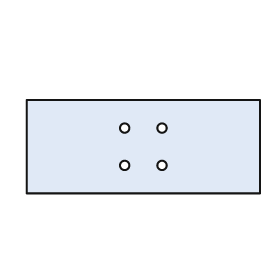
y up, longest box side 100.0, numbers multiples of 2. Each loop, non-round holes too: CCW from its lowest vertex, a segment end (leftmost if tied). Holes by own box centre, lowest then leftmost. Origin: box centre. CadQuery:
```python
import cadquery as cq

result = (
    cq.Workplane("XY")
    .moveTo(-50.0, -20.0)
    .lineTo(50.0, -20.0)
    .lineTo(50.0, 20.0)
    .lineTo(-50.0, 20.0)
    .close()
    .moveTo(-8.0, -8.0)
    .circle(2.0)
    .moveTo(8.0, -8.0)
    .circle(2.0)
    .moveTo(-8.0, 8.0)
    .circle(2.0)
    .moveTo(8.0, 8.0)
    .circle(2.0)
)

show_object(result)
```